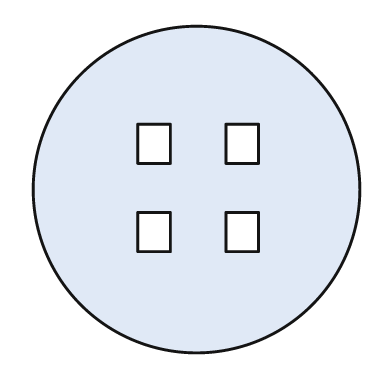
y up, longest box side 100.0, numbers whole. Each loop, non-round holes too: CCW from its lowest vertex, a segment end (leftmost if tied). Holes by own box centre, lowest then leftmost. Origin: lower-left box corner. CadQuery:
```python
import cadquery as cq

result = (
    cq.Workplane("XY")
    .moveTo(50.0, 50.0)
    .circle(50.0)
    .moveTo(32.0, 31.0)
    .lineTo(42.0, 31.0)
    .lineTo(42.0, 43.0)
    .lineTo(32.0, 43.0)
    .close()
    .moveTo(59.0, 31.0)
    .lineTo(69.0, 31.0)
    .lineTo(69.0, 43.0)
    .lineTo(59.0, 43.0)
    .close()
    .moveTo(32.0, 58.0)
    .lineTo(42.0, 58.0)
    .lineTo(42.0, 70.0)
    .lineTo(32.0, 70.0)
    .close()
    .moveTo(59.0, 58.0)
    .lineTo(69.0, 58.0)
    .lineTo(69.0, 70.0)
    .lineTo(59.0, 70.0)
    .close()
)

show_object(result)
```